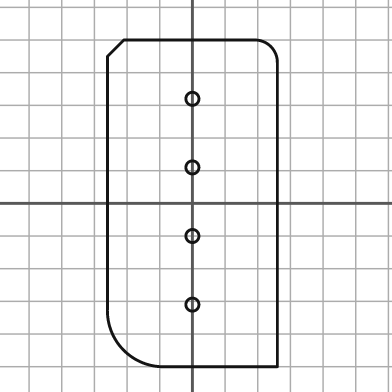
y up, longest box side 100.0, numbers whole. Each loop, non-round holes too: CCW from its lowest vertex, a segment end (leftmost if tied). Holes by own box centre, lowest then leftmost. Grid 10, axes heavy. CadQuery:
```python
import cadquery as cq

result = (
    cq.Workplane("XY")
    .moveTo(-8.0, -50.0)
    .lineTo(26.0, -50.0)
    .lineTo(26.0, 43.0)
    .threePointArc((24.0, 48.0), (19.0, 50.0))
    .lineTo(-21.0, 50.0)
    .lineTo(-26.0, 45.0)
    .lineTo(-26.0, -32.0)
    .threePointArc((-21.0, -45.0), (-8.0, -50.0))
    .close()
    .moveTo(0.0, -31.0)
    .circle(2.0)
    .moveTo(0.0, -10.0)
    .circle(2.0)
    .moveTo(0.0, 11.0)
    .circle(2.0)
    .moveTo(0.0, 32.0)
    .circle(2.0)
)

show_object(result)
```